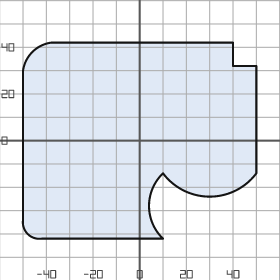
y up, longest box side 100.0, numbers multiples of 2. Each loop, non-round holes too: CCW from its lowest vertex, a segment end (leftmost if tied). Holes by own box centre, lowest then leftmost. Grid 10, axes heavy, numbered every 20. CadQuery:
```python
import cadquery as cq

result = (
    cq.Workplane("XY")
    .moveTo(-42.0, -42.0)
    .lineTo(10.0, -42.0)
    .threePointArc((4.0, -28.0), (10.0, -14.0))
    .threePointArc((30.0, -24.0), (50.0, -14.0))
    .lineTo(50.0, 32.0)
    .lineTo(40.0, 32.0)
    .lineTo(40.0, 42.0)
    .lineTo(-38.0, 42.0)
    .threePointArc((-46.0, 38.0), (-50.0, 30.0))
    .lineTo(-50.0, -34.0)
    .threePointArc((-48.0, -40.0), (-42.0, -42.0))
    .close()
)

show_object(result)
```